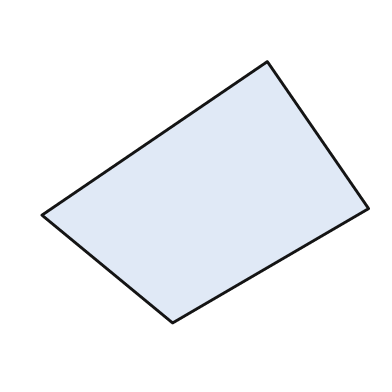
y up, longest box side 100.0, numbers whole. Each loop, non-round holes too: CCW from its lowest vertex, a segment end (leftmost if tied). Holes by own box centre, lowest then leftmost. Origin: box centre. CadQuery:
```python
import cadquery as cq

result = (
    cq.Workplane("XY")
    .moveTo(-10.0, -40.0)
    .lineTo(50.0, -5.0)
    .lineTo(19.0, 40.0)
    .lineTo(-50.0, -7.0)
    .close()
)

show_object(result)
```